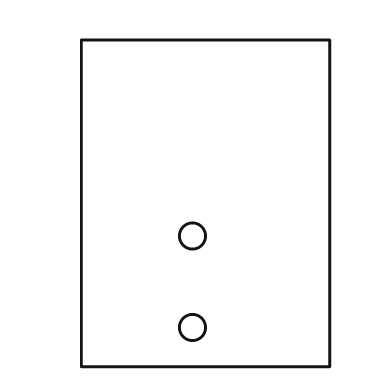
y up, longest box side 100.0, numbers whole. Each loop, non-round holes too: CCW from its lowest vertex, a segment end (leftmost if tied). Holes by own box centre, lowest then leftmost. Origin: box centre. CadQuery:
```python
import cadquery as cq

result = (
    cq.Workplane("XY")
    .moveTo(-38.0, -50.0)
    .lineTo(38.0, -50.0)
    .lineTo(38.0, 50.0)
    .lineTo(-38.0, 50.0)
    .close()
    .moveTo(-4.0, -38.0)
    .circle(4.0)
    .moveTo(-4.0, -10.0)
    .circle(4.0)
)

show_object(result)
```